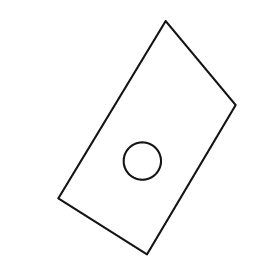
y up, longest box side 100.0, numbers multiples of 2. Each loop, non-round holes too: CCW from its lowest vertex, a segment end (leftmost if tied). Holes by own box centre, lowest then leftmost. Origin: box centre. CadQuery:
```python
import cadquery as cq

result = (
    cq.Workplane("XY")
    .moveTo(0.0, -50.0)
    .lineTo(38.0, 14.0)
    .lineTo(8.0, 50.0)
    .lineTo(-38.0, -26.0)
    .close()
    .moveTo(-2.0, -10.0)
    .circle(8.0)
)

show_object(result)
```